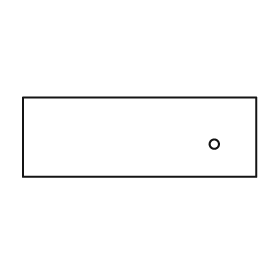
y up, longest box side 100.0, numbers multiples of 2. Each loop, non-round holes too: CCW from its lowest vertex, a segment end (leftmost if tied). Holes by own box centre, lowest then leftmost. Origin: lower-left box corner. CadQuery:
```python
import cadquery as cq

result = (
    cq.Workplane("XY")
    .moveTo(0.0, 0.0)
    .lineTo(100.0, 0.0)
    .lineTo(100.0, 34.0)
    .lineTo(0.0, 34.0)
    .close()
    .moveTo(82.0, 14.0)
    .circle(2.0)
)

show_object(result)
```